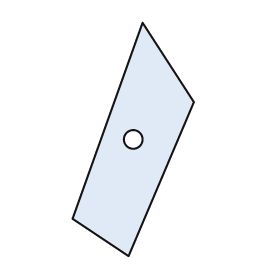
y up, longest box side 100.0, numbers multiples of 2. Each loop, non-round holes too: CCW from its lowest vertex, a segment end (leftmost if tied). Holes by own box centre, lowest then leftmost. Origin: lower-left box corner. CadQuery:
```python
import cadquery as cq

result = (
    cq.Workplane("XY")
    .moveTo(24.0, 0.0)
    .lineTo(52.0, 66.0)
    .lineTo(30.0, 100.0)
    .lineTo(0.0, 16.0)
    .close()
    .moveTo(26.0, 50.0)
    .circle(4.0)
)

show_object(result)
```